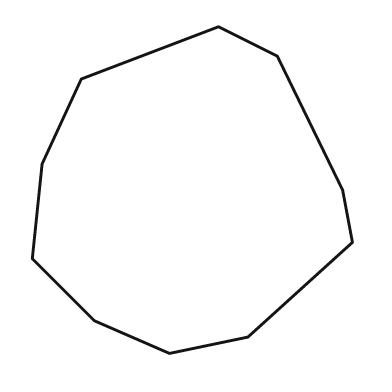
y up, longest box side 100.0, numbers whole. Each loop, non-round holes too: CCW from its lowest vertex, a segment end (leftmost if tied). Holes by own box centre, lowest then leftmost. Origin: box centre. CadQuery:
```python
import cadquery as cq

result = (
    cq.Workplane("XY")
    .moveTo(-7.0, -50.0)
    .lineTo(17.0, -45.0)
    .lineTo(49.0, -16.0)
    .lineTo(46.0, 0.0)
    .lineTo(26.0, 41.0)
    .lineTo(8.0, 50.0)
    .lineTo(-34.0, 34.0)
    .lineTo(-46.0, 8.0)
    .lineTo(-49.0, -21.0)
    .lineTo(-30.0, -40.0)
    .close()
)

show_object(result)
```